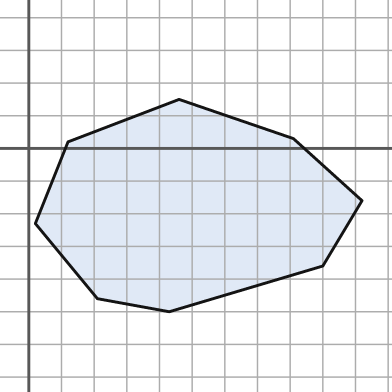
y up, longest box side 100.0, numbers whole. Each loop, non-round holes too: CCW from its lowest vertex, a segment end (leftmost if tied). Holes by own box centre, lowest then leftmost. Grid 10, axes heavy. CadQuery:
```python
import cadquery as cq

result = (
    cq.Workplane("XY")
    .moveTo(43.0, -50.0)
    .lineTo(90.0, -36.0)
    .lineTo(102.0, -16.0)
    .lineTo(81.0, 3.0)
    .lineTo(46.0, 15.0)
    .lineTo(12.0, 2.0)
    .lineTo(2.0, -23.0)
    .lineTo(21.0, -46.0)
    .close()
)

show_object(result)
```